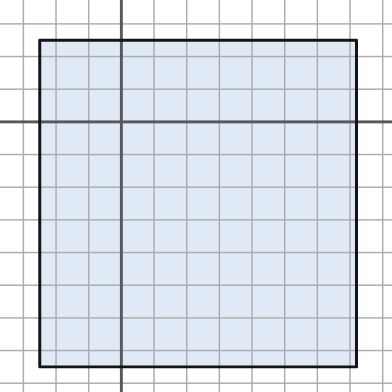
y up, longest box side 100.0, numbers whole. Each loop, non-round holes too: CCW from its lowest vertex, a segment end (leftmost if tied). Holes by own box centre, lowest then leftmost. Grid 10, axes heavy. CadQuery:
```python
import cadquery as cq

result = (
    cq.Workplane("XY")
    .moveTo(-25.0, -75.0)
    .lineTo(72.0, -75.0)
    .lineTo(72.0, 25.0)
    .lineTo(-25.0, 25.0)
    .close()
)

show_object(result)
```